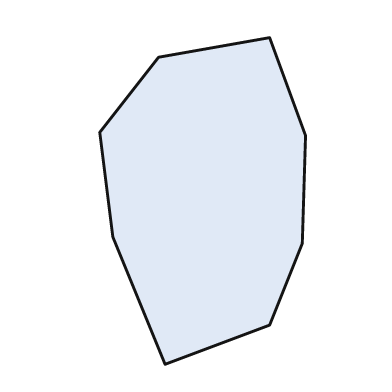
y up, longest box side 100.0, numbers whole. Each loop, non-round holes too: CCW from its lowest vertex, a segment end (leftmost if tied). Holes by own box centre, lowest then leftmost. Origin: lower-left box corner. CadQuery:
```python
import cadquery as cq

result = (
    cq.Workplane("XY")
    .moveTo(20.0, 0.0)
    .lineTo(52.0, 12.0)
    .lineTo(62.0, 37.0)
    .lineTo(63.0, 70.0)
    .lineTo(52.0, 100.0)
    .lineTo(18.0, 94.0)
    .lineTo(0.0, 71.0)
    .lineTo(4.0, 39.0)
    .close()
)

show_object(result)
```